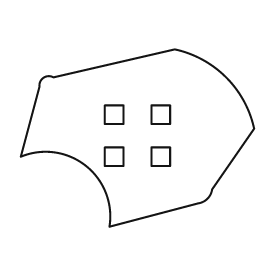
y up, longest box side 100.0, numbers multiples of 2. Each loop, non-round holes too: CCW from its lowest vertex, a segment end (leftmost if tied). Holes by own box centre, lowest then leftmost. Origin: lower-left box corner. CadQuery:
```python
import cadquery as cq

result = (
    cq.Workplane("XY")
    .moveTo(38.0, 0.0)
    .lineTo(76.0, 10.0)
    .threePointArc((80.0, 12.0), (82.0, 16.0))
    .lineTo(100.0, 42.0)
    .threePointArc((88.0, 64.0), (66.0, 76.0))
    .lineTo(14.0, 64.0)
    .threePointArc((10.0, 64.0), (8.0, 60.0))
    .lineTo(0.0, 30.0)
    .threePointArc((28.0, 26.0), (38.0, 0.0))
    .close()
    .moveTo(36.0, 26.0)
    .lineTo(44.0, 26.0)
    .lineTo(44.0, 34.0)
    .lineTo(36.0, 34.0)
    .close()
    .moveTo(56.0, 26.0)
    .lineTo(64.0, 26.0)
    .lineTo(64.0, 34.0)
    .lineTo(56.0, 34.0)
    .close()
    .moveTo(36.0, 44.0)
    .lineTo(44.0, 44.0)
    .lineTo(44.0, 52.0)
    .lineTo(36.0, 52.0)
    .close()
    .moveTo(56.0, 44.0)
    .lineTo(64.0, 44.0)
    .lineTo(64.0, 52.0)
    .lineTo(56.0, 52.0)
    .close()
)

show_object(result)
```